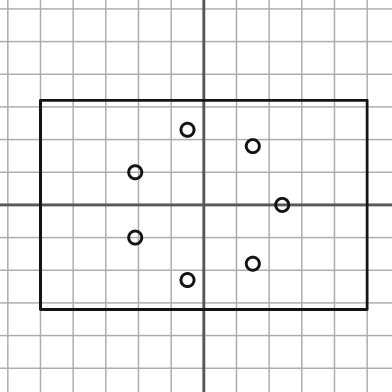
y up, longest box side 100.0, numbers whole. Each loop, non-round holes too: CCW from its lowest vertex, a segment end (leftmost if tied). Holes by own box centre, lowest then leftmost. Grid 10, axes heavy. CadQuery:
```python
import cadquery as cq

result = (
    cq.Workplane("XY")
    .moveTo(-50.0, -32.0)
    .lineTo(50.0, -32.0)
    .lineTo(50.0, 32.0)
    .lineTo(-50.0, 32.0)
    .close()
    .moveTo(-5.0, -23.0)
    .circle(2.0)
    .moveTo(15.0, -18.0)
    .circle(2.0)
    .moveTo(-21.0, -10.0)
    .circle(2.0)
    .moveTo(24.0, 0.0)
    .circle(2.0)
    .moveTo(-21.0, 10.0)
    .circle(2.0)
    .moveTo(15.0, 18.0)
    .circle(2.0)
    .moveTo(-5.0, 23.0)
    .circle(2.0)
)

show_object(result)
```